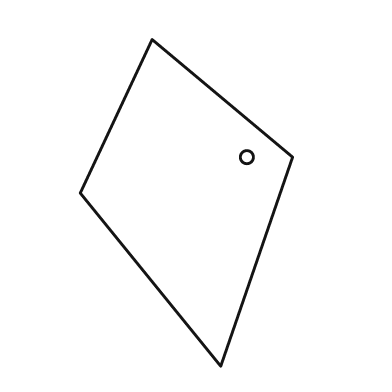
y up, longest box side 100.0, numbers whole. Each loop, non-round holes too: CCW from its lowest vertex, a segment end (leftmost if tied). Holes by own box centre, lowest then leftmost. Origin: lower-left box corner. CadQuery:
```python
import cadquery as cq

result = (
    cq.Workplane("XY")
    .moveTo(43.0, 0.0)
    .lineTo(65.0, 64.0)
    .lineTo(22.0, 100.0)
    .lineTo(0.0, 53.0)
    .close()
    .moveTo(51.0, 64.0)
    .circle(2.0)
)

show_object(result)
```